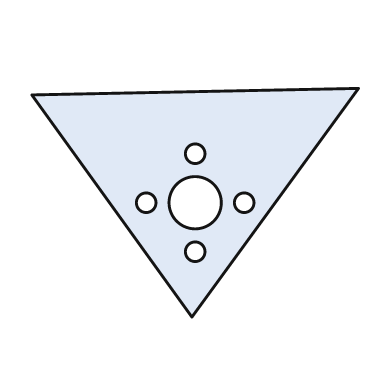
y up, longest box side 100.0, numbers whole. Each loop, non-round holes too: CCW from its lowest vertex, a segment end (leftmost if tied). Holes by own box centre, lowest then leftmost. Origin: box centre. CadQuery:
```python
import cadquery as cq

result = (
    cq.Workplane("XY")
    .moveTo(-1.0, -35.0)
    .lineTo(50.0, 35.0)
    .lineTo(-50.0, 33.0)
    .close()
    .moveTo(0.0, -15.0)
    .circle(3.0)
    .moveTo(-15.0, 0.0)
    .circle(3.0)
    .moveTo(0.0, 0.0)
    .circle(8.0)
    .moveTo(15.0, 0.0)
    .circle(3.0)
    .moveTo(0.0, 15.0)
    .circle(3.0)
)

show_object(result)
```